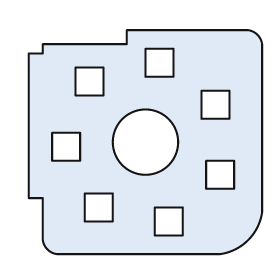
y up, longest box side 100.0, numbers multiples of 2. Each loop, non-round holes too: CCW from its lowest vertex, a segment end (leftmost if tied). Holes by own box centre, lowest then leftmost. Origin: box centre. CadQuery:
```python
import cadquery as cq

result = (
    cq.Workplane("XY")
    .moveTo(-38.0, -48.0)
    .lineTo(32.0, -48.0)
    .threePointArc((44.0, -42.0), (50.0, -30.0))
    .lineTo(50.0, 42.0)
    .threePointArc((48.0, 46.0), (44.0, 48.0))
    .lineTo(-8.0, 48.0)
    .lineTo(-8.0, 42.0)
    .lineTo(-44.0, 42.0)
    .lineTo(-44.0, 38.0)
    .lineTo(-50.0, 38.0)
    .lineTo(-50.0, -24.0)
    .lineTo(-44.0, -24.0)
    .lineTo(-44.0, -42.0)
    .threePointArc((-42.0, -46.0), (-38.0, -48.0))
    .close()
    .moveTo(4.0, -40.0)
    .lineTo(16.0, -40.0)
    .lineTo(16.0, -28.0)
    .lineTo(4.0, -28.0)
    .close()
    .moveTo(-26.0, -34.0)
    .lineTo(-14.0, -34.0)
    .lineTo(-14.0, -22.0)
    .lineTo(-26.0, -22.0)
    .close()
    .moveTo(26.0, -20.0)
    .lineTo(38.0, -20.0)
    .lineTo(38.0, -8.0)
    .lineTo(26.0, -8.0)
    .close()
    .moveTo(-40.0, -8.0)
    .lineTo(-28.0, -8.0)
    .lineTo(-28.0, 4.0)
    .lineTo(-40.0, 4.0)
    .close()
    .moveTo(0.0, 0.0)
    .circle(14.0)
    .moveTo(24.0, 10.0)
    .lineTo(36.0, 10.0)
    .lineTo(36.0, 22.0)
    .lineTo(24.0, 22.0)
    .close()
    .moveTo(-30.0, 20.0)
    .lineTo(-18.0, 20.0)
    .lineTo(-18.0, 32.0)
    .lineTo(-30.0, 32.0)
    .close()
    .moveTo(0.0, 28.0)
    .lineTo(12.0, 28.0)
    .lineTo(12.0, 40.0)
    .lineTo(0.0, 40.0)
    .close()
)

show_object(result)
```